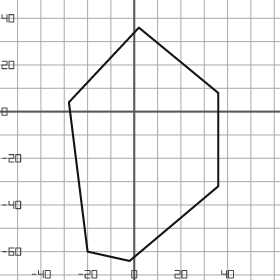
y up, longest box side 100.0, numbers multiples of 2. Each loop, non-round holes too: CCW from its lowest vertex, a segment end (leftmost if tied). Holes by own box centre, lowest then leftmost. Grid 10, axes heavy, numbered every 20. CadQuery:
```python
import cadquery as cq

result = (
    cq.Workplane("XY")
    .moveTo(-2.0, -64.0)
    .lineTo(36.0, -32.0)
    .lineTo(36.0, 8.0)
    .lineTo(2.0, 36.0)
    .lineTo(-28.0, 4.0)
    .lineTo(-20.0, -60.0)
    .close()
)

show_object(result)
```